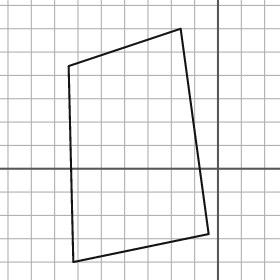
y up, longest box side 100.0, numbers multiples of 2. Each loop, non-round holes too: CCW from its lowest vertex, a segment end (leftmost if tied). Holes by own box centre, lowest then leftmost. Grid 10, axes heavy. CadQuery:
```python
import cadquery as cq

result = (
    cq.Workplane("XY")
    .moveTo(-62.0, -40.0)
    .lineTo(-4.0, -28.0)
    .lineTo(-16.0, 60.0)
    .lineTo(-64.0, 44.0)
    .close()
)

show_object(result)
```